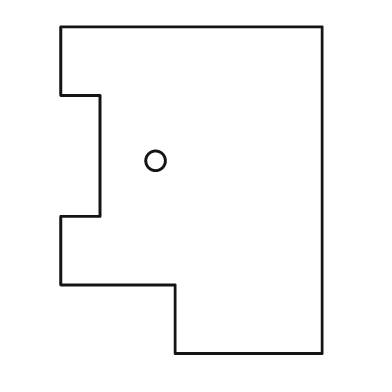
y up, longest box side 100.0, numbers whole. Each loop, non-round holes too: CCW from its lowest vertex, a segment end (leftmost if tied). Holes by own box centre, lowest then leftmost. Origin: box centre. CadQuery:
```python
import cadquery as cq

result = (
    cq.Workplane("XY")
    .moveTo(-5.0, -50.0)
    .lineTo(40.0, -50.0)
    .lineTo(40.0, 50.0)
    .lineTo(-40.0, 50.0)
    .lineTo(-40.0, 29.0)
    .lineTo(-28.0, 29.0)
    .lineTo(-28.0, -8.0)
    .lineTo(-40.0, -8.0)
    .lineTo(-40.0, -29.0)
    .lineTo(-5.0, -29.0)
    .close()
    .moveTo(-11.0, 9.0)
    .circle(3.0)
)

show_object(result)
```